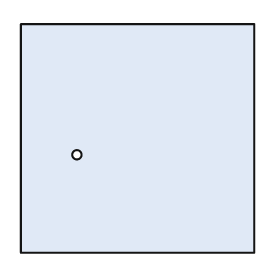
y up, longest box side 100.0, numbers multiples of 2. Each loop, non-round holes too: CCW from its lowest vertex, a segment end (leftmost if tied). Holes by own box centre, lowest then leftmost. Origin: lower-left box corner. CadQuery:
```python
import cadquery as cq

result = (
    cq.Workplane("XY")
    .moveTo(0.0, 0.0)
    .lineTo(100.0, 0.0)
    .lineTo(100.0, 98.0)
    .lineTo(0.0, 98.0)
    .close()
    .moveTo(24.0, 42.0)
    .circle(2.0)
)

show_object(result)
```